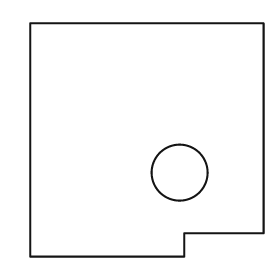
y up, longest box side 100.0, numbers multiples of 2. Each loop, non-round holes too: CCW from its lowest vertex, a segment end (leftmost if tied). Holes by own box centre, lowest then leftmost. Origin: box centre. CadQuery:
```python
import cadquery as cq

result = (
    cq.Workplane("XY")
    .moveTo(-50.0, -50.0)
    .lineTo(16.0, -50.0)
    .lineTo(16.0, -40.0)
    .lineTo(50.0, -40.0)
    .lineTo(50.0, 50.0)
    .lineTo(-50.0, 50.0)
    .close()
    .moveTo(14.0, -14.0)
    .circle(12.0)
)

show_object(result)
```